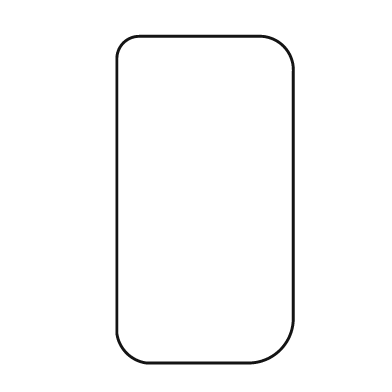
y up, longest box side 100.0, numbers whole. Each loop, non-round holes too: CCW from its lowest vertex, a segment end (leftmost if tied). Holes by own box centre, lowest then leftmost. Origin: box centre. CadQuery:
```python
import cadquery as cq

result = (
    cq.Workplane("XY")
    .moveTo(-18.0, -50.0)
    .lineTo(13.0, -50.0)
    .threePointArc((23.0, -46.0), (27.0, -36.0))
    .lineTo(27.0, 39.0)
    .threePointArc((24.0, 47.0), (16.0, 50.0))
    .lineTo(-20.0, 50.0)
    .threePointArc((-25.0, 48.0), (-27.0, 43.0))
    .lineTo(-27.0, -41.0)
    .threePointArc((-24.0, -47.0), (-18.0, -50.0))
    .close()
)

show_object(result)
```